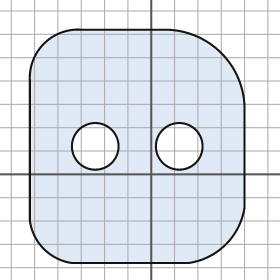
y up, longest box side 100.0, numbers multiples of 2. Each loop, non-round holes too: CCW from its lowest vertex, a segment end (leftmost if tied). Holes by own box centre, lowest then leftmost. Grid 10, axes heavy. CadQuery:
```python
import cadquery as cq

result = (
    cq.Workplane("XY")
    .moveTo(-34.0, -38.0)
    .lineTo(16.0, -38.0)
    .threePointArc((32.0, -30.0), (40.0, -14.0))
    .lineTo(40.0, 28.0)
    .threePointArc((30.0, 52.0), (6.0, 62.0))
    .lineTo(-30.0, 62.0)
    .threePointArc((-46.0, 56.0), (-52.0, 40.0))
    .lineTo(-52.0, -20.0)
    .threePointArc((-46.0, -32.0), (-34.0, -38.0))
    .close()
    .moveTo(-24.0, 12.0)
    .circle(10.0)
    .moveTo(12.0, 12.0)
    .circle(10.0)
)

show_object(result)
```